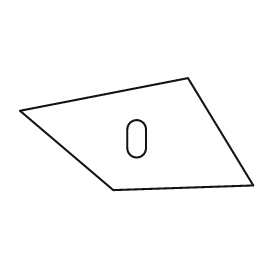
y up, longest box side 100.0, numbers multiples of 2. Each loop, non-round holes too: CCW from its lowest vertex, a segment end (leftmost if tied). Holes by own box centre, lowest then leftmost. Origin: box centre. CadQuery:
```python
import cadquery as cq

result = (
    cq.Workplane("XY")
    .moveTo(-10.0, -24.0)
    .lineTo(50.0, -22.0)
    .lineTo(22.0, 24.0)
    .lineTo(-50.0, 10.0)
    .close()
    .moveTo(-4.0, -6.0)
    .threePointArc((0.0, -10.0), (4.0, -6.0))
    .lineTo(4.0, 2.0)
    .threePointArc((0.0, 6.0), (-4.0, 2.0))
    .close()
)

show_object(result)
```